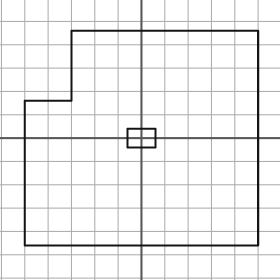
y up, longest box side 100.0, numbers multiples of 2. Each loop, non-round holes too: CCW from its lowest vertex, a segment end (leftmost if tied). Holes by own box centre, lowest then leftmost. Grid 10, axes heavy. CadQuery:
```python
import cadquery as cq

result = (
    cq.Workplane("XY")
    .moveTo(-50.0, -46.0)
    .lineTo(50.0, -46.0)
    .lineTo(50.0, 46.0)
    .lineTo(-30.0, 46.0)
    .lineTo(-30.0, 16.0)
    .lineTo(-50.0, 16.0)
    .close()
    .moveTo(-6.0, -4.0)
    .lineTo(6.0, -4.0)
    .lineTo(6.0, 4.0)
    .lineTo(-6.0, 4.0)
    .close()
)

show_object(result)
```